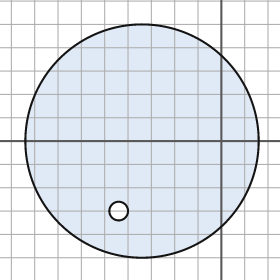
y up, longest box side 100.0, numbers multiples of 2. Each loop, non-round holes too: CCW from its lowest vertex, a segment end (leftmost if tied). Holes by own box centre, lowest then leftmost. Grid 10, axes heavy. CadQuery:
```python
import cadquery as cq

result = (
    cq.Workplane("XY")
    .moveTo(-34.0, 0.0)
    .circle(50.0)
    .moveTo(-44.0, -30.0)
    .circle(4.0)
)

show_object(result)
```